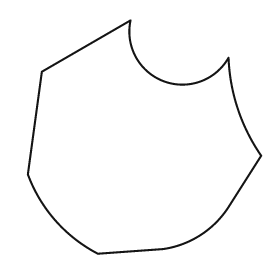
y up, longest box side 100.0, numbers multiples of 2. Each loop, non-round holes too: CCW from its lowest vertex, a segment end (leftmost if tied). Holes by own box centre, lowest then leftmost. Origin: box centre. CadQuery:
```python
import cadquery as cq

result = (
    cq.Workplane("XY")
    .moveTo(-20.0, -50.0)
    .lineTo(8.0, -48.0)
    .threePointArc((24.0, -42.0), (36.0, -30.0))
    .lineTo(50.0, -8.0)
    .threePointArc((40.0, 12.0), (36.0, 34.0))
    .threePointArc((8.0, 24.0), (-6.0, 50.0))
    .lineTo(-44.0, 28.0)
    .lineTo(-50.0, -16.0)
    .threePointArc((-38.0, -36.0), (-20.0, -50.0))
    .close()
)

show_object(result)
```